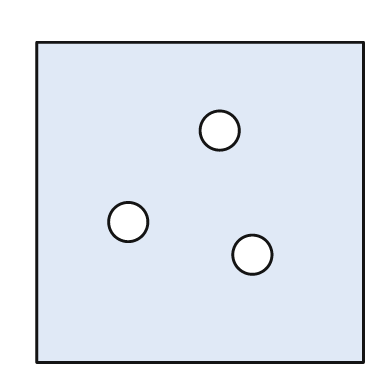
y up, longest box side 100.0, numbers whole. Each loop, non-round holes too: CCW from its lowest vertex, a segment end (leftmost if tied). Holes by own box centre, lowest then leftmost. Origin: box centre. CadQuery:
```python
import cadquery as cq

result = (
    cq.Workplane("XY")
    .moveTo(-50.0, -49.0)
    .lineTo(50.0, -49.0)
    .lineTo(50.0, 49.0)
    .lineTo(-50.0, 49.0)
    .close()
    .moveTo(16.0, -16.0)
    .circle(6.0)
    .moveTo(-22.0, -6.0)
    .circle(6.0)
    .moveTo(6.0, 22.0)
    .circle(6.0)
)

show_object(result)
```